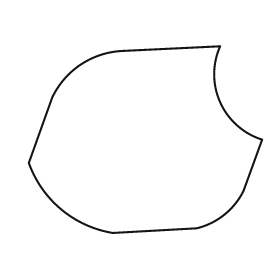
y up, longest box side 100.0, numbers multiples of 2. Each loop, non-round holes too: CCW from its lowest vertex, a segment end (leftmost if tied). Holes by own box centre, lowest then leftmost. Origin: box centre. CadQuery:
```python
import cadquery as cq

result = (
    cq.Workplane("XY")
    .moveTo(-14.0, -40.0)
    .lineTo(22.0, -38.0)
    .threePointArc((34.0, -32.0), (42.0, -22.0))
    .lineTo(50.0, 0.0)
    .threePointArc((32.0, 16.0), (32.0, 40.0))
    .lineTo(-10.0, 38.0)
    .threePointArc((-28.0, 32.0), (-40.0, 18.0))
    .lineTo(-50.0, -10.0)
    .threePointArc((-36.0, -30.0), (-14.0, -40.0))
    .close()
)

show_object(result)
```